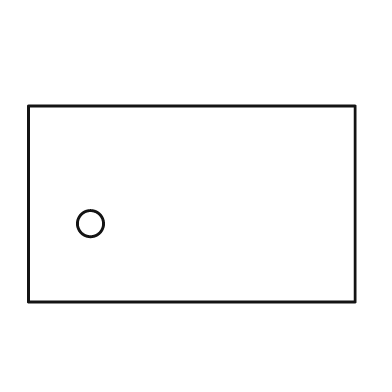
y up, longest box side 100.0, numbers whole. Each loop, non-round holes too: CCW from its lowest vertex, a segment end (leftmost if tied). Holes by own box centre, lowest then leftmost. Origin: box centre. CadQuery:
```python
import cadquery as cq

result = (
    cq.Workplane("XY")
    .moveTo(-50.0, -30.0)
    .lineTo(50.0, -30.0)
    .lineTo(50.0, 30.0)
    .lineTo(-50.0, 30.0)
    .close()
    .moveTo(-31.0, -6.0)
    .circle(4.0)
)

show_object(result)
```